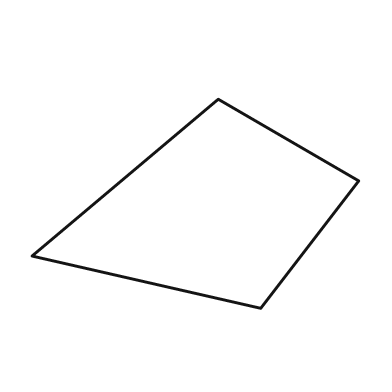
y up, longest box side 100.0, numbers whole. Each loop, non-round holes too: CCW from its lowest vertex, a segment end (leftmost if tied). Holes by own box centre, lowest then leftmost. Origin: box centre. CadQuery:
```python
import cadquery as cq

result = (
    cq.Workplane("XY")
    .moveTo(20.0, -32.0)
    .lineTo(50.0, 7.0)
    .lineTo(7.0, 32.0)
    .lineTo(-50.0, -16.0)
    .close()
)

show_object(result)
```